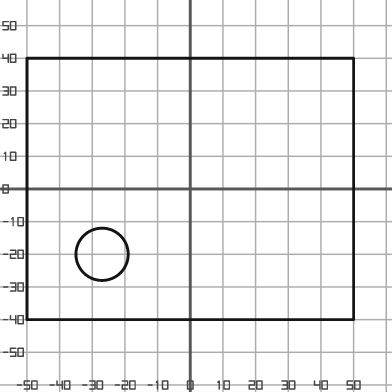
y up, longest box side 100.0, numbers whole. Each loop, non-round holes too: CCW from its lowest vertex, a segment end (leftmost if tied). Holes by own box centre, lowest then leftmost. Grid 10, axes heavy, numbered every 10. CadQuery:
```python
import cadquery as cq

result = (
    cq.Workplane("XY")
    .moveTo(-50.0, -40.0)
    .lineTo(50.0, -40.0)
    .lineTo(50.0, 40.0)
    .lineTo(-50.0, 40.0)
    .close()
    .moveTo(-27.0, -20.0)
    .circle(8.0)
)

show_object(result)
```